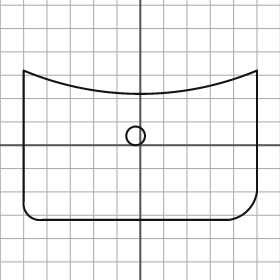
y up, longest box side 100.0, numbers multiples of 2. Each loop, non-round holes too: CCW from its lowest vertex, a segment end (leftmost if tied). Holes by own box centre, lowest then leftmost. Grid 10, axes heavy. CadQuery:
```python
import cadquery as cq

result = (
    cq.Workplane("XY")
    .moveTo(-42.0, -32.0)
    .lineTo(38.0, -32.0)
    .threePointArc((46.0, -28.0), (50.0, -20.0))
    .lineTo(50.0, 32.0)
    .threePointArc((0.0, 22.0), (-50.0, 32.0))
    .lineTo(-50.0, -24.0)
    .threePointArc((-48.0, -30.0), (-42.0, -32.0))
    .close()
    .moveTo(-2.0, 4.0)
    .circle(4.0)
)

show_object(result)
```